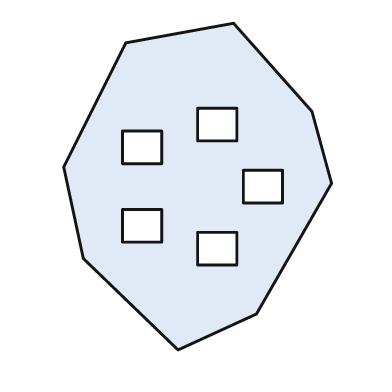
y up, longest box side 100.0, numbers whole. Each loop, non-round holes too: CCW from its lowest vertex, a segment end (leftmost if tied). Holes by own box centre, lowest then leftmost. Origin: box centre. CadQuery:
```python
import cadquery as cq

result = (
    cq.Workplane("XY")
    .moveTo(-6.0, -50.0)
    .lineTo(18.0, -39.0)
    .lineTo(41.0, 1.0)
    .lineTo(35.0, 23.0)
    .lineTo(11.0, 50.0)
    .lineTo(-22.0, 44.0)
    .lineTo(-41.0, 6.0)
    .lineTo(-35.0, -22.0)
    .close()
    .moveTo(0.0, -24.0)
    .lineTo(12.0, -24.0)
    .lineTo(12.0, -14.0)
    .lineTo(0.0, -14.0)
    .close()
    .moveTo(-23.0, -17.0)
    .lineTo(-11.0, -17.0)
    .lineTo(-11.0, -7.0)
    .lineTo(-23.0, -7.0)
    .close()
    .moveTo(14.0, -5.0)
    .lineTo(26.0, -5.0)
    .lineTo(26.0, 5.0)
    .lineTo(14.0, 5.0)
    .close()
    .moveTo(-23.0, 7.0)
    .lineTo(-11.0, 7.0)
    .lineTo(-11.0, 17.0)
    .lineTo(-23.0, 17.0)
    .close()
    .moveTo(0.0, 14.0)
    .lineTo(12.0, 14.0)
    .lineTo(12.0, 24.0)
    .lineTo(0.0, 24.0)
    .close()
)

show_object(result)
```